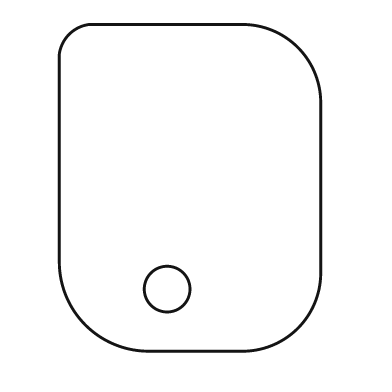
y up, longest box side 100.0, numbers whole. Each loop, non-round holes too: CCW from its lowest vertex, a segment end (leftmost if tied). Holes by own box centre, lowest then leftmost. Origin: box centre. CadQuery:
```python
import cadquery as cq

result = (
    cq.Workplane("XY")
    .moveTo(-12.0, -50.0)
    .lineTo(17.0, -50.0)
    .threePointArc((33.0, -43.0), (40.0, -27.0))
    .lineTo(40.0, 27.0)
    .threePointArc((33.0, 43.0), (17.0, 50.0))
    .lineTo(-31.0, 50.0)
    .threePointArc((-37.0, 47.0), (-40.0, 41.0))
    .lineTo(-40.0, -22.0)
    .threePointArc((-32.0, -42.0), (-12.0, -50.0))
    .close()
    .moveTo(-7.0, -31.0)
    .circle(7.0)
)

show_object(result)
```